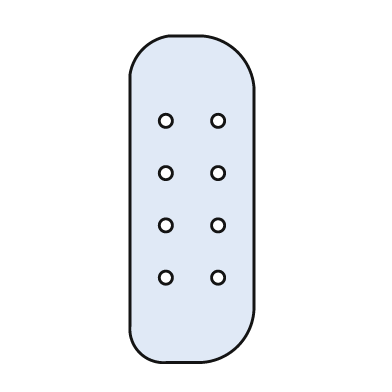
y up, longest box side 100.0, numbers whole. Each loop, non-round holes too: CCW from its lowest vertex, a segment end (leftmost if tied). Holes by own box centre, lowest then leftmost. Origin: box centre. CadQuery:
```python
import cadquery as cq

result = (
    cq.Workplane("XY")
    .moveTo(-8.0, -50.0)
    .lineTo(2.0, -50.0)
    .threePointArc((14.0, -45.0), (19.0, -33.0))
    .lineTo(19.0, 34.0)
    .threePointArc((14.0, 45.0), (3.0, 50.0))
    .lineTo(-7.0, 50.0)
    .threePointArc((-15.0, 46.0), (-19.0, 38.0))
    .lineTo(-19.0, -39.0)
    .threePointArc((-16.0, -47.0), (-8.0, -50.0))
    .close()
    .moveTo(-8.0, -24.0)
    .circle(2.0)
    .moveTo(8.0, -24.0)
    .circle(2.0)
    .moveTo(-8.0, -8.0)
    .circle(2.0)
    .moveTo(8.0, -8.0)
    .circle(2.0)
    .moveTo(-8.0, 8.0)
    .circle(2.0)
    .moveTo(8.0, 8.0)
    .circle(2.0)
    .moveTo(-8.0, 24.0)
    .circle(2.0)
    .moveTo(8.0, 24.0)
    .circle(2.0)
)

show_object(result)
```